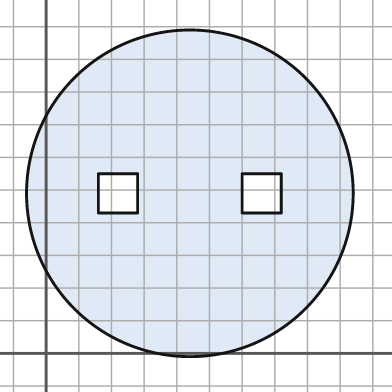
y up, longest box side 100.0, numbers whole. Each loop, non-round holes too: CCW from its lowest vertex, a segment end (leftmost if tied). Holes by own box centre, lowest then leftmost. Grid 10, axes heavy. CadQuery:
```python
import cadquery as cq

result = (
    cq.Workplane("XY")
    .moveTo(44.0, 49.0)
    .circle(50.0)
    .moveTo(16.0, 43.0)
    .lineTo(28.0, 43.0)
    .lineTo(28.0, 55.0)
    .lineTo(16.0, 55.0)
    .close()
    .moveTo(60.0, 43.0)
    .lineTo(72.0, 43.0)
    .lineTo(72.0, 55.0)
    .lineTo(60.0, 55.0)
    .close()
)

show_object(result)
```